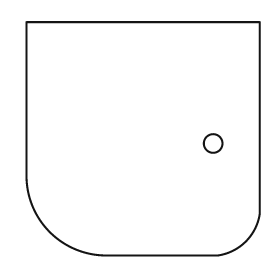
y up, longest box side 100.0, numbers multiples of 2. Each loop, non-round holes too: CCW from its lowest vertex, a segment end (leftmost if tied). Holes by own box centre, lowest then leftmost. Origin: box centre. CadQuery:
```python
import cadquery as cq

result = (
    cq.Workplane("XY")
    .moveTo(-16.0, -50.0)
    .lineTo(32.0, -50.0)
    .threePointArc((44.0, -44.0), (50.0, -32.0))
    .lineTo(50.0, 50.0)
    .lineTo(-50.0, 50.0)
    .lineTo(-50.0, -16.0)
    .threePointArc((-40.0, -40.0), (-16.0, -50.0))
    .close()
    .moveTo(30.0, -2.0)
    .circle(4.0)
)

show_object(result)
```